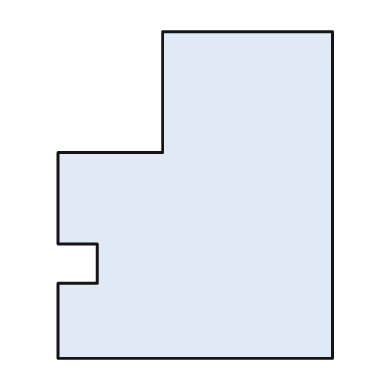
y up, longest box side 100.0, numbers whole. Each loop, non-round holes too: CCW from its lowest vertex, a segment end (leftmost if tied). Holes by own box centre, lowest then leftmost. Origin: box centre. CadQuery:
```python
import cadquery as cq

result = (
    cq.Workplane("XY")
    .moveTo(-42.0, -50.0)
    .lineTo(42.0, -50.0)
    .lineTo(42.0, 50.0)
    .lineTo(-10.0, 50.0)
    .lineTo(-10.0, 13.0)
    .lineTo(-42.0, 13.0)
    .lineTo(-42.0, -15.0)
    .lineTo(-30.0, -15.0)
    .lineTo(-30.0, -27.0)
    .lineTo(-42.0, -27.0)
    .close()
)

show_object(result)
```